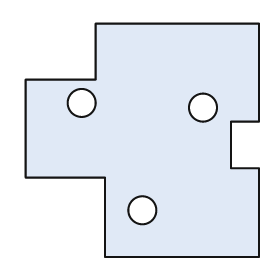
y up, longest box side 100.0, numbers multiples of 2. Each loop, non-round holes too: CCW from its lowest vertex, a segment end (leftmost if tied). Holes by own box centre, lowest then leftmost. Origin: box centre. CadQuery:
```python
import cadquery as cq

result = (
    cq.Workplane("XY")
    .moveTo(-16.0, -50.0)
    .lineTo(50.0, -50.0)
    .lineTo(50.0, -12.0)
    .lineTo(38.0, -12.0)
    .lineTo(38.0, 8.0)
    .lineTo(50.0, 8.0)
    .lineTo(50.0, 50.0)
    .lineTo(-20.0, 50.0)
    .lineTo(-20.0, 26.0)
    .lineTo(-50.0, 26.0)
    .lineTo(-50.0, -16.0)
    .lineTo(-16.0, -16.0)
    .close()
    .moveTo(0.0, -30.0)
    .circle(6.0)
    .moveTo(26.0, 14.0)
    .circle(6.0)
    .moveTo(-26.0, 16.0)
    .circle(6.0)
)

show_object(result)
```